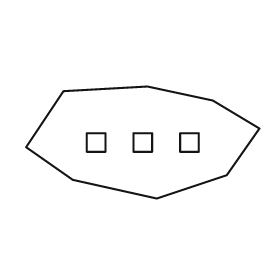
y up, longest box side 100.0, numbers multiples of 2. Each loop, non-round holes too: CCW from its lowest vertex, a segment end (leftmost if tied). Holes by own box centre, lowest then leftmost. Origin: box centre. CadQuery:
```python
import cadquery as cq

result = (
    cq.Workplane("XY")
    .moveTo(6.0, -24.0)
    .lineTo(36.0, -14.0)
    .lineTo(50.0, 6.0)
    .lineTo(30.0, 18.0)
    .lineTo(2.0, 24.0)
    .lineTo(-34.0, 22.0)
    .lineTo(-50.0, -2.0)
    .lineTo(-30.0, -16.0)
    .close()
    .moveTo(-24.0, -4.0)
    .lineTo(-16.0, -4.0)
    .lineTo(-16.0, 4.0)
    .lineTo(-24.0, 4.0)
    .close()
    .moveTo(-4.0, -4.0)
    .lineTo(4.0, -4.0)
    .lineTo(4.0, 4.0)
    .lineTo(-4.0, 4.0)
    .close()
    .moveTo(16.0, -4.0)
    .lineTo(24.0, -4.0)
    .lineTo(24.0, 4.0)
    .lineTo(16.0, 4.0)
    .close()
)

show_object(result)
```